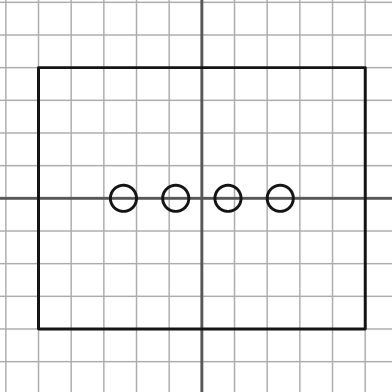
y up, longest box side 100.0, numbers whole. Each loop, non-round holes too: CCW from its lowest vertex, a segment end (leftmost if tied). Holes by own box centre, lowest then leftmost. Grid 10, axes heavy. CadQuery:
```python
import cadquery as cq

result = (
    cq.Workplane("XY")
    .moveTo(-50.0, -40.0)
    .lineTo(50.0, -40.0)
    .lineTo(50.0, 40.0)
    .lineTo(-50.0, 40.0)
    .close()
    .moveTo(-24.0, 0.0)
    .circle(4.0)
    .moveTo(-8.0, 0.0)
    .circle(4.0)
    .moveTo(8.0, 0.0)
    .circle(4.0)
    .moveTo(24.0, 0.0)
    .circle(4.0)
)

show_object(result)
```